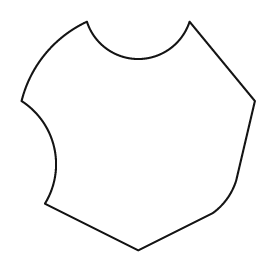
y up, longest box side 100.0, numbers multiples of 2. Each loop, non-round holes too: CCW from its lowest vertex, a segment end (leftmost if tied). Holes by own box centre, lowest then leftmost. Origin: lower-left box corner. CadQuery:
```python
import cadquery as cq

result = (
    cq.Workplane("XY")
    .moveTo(50.0, 0.0)
    .lineTo(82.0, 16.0)
    .threePointArc((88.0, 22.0), (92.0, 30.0))
    .lineTo(100.0, 64.0)
    .lineTo(72.0, 98.0)
    .threePointArc((50.0, 82.0), (28.0, 98.0))
    .threePointArc((10.0, 84.0), (0.0, 64.0))
    .threePointArc((14.0, 44.0), (10.0, 20.0))
    .close()
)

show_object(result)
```